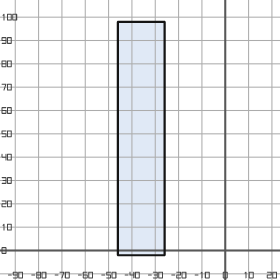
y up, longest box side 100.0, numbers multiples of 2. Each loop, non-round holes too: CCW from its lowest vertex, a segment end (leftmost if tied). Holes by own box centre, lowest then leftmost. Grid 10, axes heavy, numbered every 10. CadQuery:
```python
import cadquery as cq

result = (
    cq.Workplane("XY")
    .moveTo(-46.0, -2.0)
    .lineTo(-26.0, -2.0)
    .lineTo(-26.0, 98.0)
    .lineTo(-46.0, 98.0)
    .close()
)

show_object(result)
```